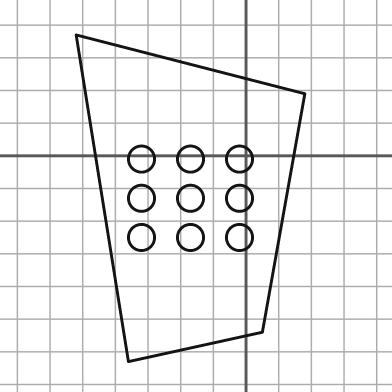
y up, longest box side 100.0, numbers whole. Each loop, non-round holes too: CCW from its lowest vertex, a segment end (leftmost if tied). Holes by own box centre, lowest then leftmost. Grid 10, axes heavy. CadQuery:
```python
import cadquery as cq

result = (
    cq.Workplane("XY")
    .moveTo(-36.0, -63.0)
    .lineTo(5.0, -54.0)
    .lineTo(18.0, 19.0)
    .lineTo(-52.0, 37.0)
    .close()
    .moveTo(-32.0, -25.0)
    .circle(4.0)
    .moveTo(-17.0, -25.0)
    .circle(4.0)
    .moveTo(-2.0, -25.0)
    .circle(4.0)
    .moveTo(-32.0, -13.0)
    .circle(4.0)
    .moveTo(-17.0, -13.0)
    .circle(4.0)
    .moveTo(-2.0, -13.0)
    .circle(4.0)
    .moveTo(-32.0, -1.0)
    .circle(4.0)
    .moveTo(-17.0, -1.0)
    .circle(4.0)
    .moveTo(-2.0, -1.0)
    .circle(4.0)
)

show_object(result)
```